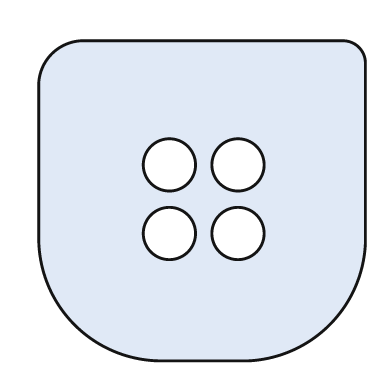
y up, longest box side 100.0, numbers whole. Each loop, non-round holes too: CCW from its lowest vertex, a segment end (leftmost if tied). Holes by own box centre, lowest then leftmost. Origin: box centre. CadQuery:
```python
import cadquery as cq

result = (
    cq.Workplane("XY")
    .moveTo(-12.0, -49.0)
    .lineTo(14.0, -49.0)
    .threePointArc((39.0, -38.0), (50.0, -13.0))
    .lineTo(50.0, 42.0)
    .threePointArc((48.0, 47.0), (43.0, 49.0))
    .lineTo(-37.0, 49.0)
    .threePointArc((-46.0, 45.0), (-50.0, 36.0))
    .lineTo(-50.0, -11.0)
    .threePointArc((-39.0, -38.0), (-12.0, -49.0))
    .close()
    .moveTo(-10.0, -10.0)
    .circle(8.0)
    .moveTo(11.0, -10.0)
    .circle(8.0)
    .moveTo(-10.0, 11.0)
    .circle(8.0)
    .moveTo(11.0, 11.0)
    .circle(8.0)
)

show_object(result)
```